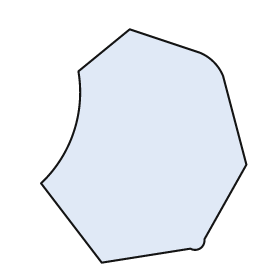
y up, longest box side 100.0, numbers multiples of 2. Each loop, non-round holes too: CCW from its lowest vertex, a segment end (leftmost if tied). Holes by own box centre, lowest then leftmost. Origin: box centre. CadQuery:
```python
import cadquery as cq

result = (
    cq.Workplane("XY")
    .moveTo(-18.0, -50.0)
    .lineTo(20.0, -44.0)
    .threePointArc((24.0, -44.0), (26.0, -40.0))
    .lineTo(44.0, -8.0)
    .lineTo(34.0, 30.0)
    .threePointArc((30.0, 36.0), (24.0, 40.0))
    .lineTo(-6.0, 50.0)
    .lineTo(-28.0, 32.0)
    .threePointArc((-30.0, 6.0), (-44.0, -16.0))
    .close()
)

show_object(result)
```